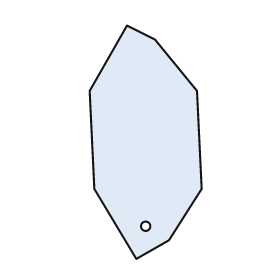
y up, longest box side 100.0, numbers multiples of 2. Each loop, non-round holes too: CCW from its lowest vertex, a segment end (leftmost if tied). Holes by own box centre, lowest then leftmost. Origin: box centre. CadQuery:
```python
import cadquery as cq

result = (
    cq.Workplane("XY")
    .moveTo(-4.0, -50.0)
    .lineTo(10.0, -42.0)
    .lineTo(24.0, -20.0)
    .lineTo(22.0, 22.0)
    .lineTo(4.0, 44.0)
    .lineTo(-8.0, 50.0)
    .lineTo(-24.0, 22.0)
    .lineTo(-22.0, -20.0)
    .close()
    .moveTo(0.0, -36.0)
    .circle(2.0)
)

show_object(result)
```